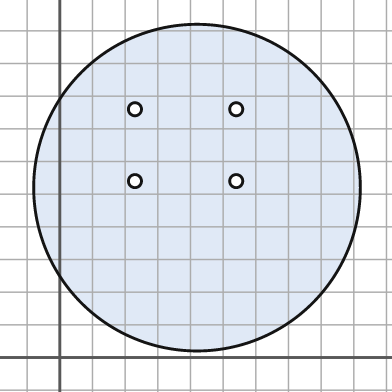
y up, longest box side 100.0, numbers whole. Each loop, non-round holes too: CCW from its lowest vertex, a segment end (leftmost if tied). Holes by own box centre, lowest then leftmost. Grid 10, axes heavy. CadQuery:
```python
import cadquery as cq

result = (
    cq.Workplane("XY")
    .moveTo(42.0, 52.0)
    .circle(50.0)
    .moveTo(23.0, 54.0)
    .circle(2.0)
    .moveTo(54.0, 54.0)
    .circle(2.0)
    .moveTo(23.0, 76.0)
    .circle(2.0)
    .moveTo(54.0, 76.0)
    .circle(2.0)
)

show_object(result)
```